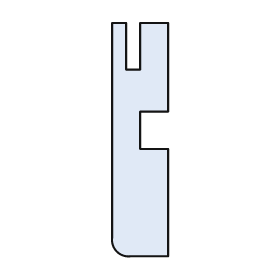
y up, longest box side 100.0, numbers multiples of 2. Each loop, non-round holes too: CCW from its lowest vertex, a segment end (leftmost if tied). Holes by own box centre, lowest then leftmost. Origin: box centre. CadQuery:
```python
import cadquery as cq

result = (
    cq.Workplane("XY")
    .moveTo(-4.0, -50.0)
    .lineTo(12.0, -50.0)
    .lineTo(12.0, -4.0)
    .lineTo(0.0, -4.0)
    .lineTo(0.0, 12.0)
    .lineTo(12.0, 12.0)
    .lineTo(12.0, 50.0)
    .lineTo(0.0, 50.0)
    .lineTo(0.0, 30.0)
    .lineTo(-6.0, 30.0)
    .lineTo(-6.0, 50.0)
    .lineTo(-12.0, 50.0)
    .lineTo(-12.0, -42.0)
    .threePointArc((-10.0, -48.0), (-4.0, -50.0))
    .close()
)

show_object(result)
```